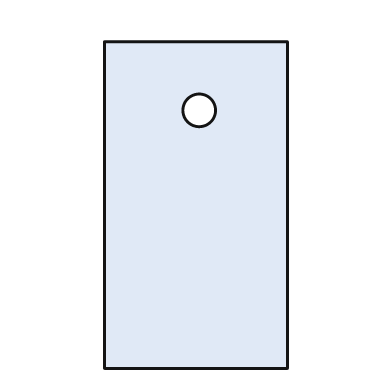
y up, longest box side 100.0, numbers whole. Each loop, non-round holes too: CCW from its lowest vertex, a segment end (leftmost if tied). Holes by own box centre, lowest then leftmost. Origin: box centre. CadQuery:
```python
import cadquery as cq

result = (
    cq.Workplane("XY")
    .moveTo(-28.0, -50.0)
    .lineTo(28.0, -50.0)
    .lineTo(28.0, 50.0)
    .lineTo(-28.0, 50.0)
    .close()
    .moveTo(1.0, 29.0)
    .circle(5.0)
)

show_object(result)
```